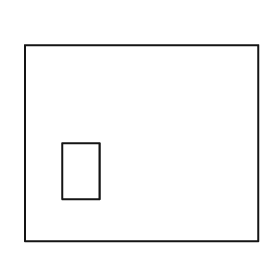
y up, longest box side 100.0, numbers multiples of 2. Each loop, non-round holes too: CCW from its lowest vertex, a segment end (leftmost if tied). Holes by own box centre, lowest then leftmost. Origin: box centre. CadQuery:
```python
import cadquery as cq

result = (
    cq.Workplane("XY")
    .moveTo(-50.0, -42.0)
    .lineTo(50.0, -42.0)
    .lineTo(50.0, 42.0)
    .lineTo(-50.0, 42.0)
    .close()
    .moveTo(-34.0, -24.0)
    .lineTo(-18.0, -24.0)
    .lineTo(-18.0, 0.0)
    .lineTo(-34.0, 0.0)
    .close()
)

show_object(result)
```